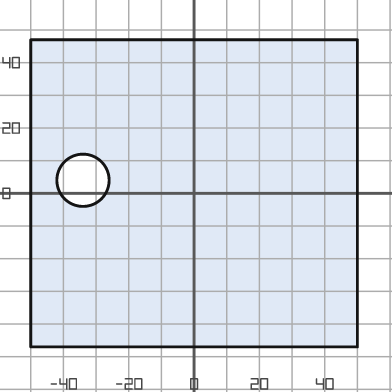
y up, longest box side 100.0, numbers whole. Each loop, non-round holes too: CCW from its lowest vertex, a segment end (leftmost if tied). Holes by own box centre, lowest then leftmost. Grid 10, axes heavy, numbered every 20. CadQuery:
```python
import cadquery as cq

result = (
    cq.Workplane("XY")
    .moveTo(-50.0, -47.0)
    .lineTo(50.0, -47.0)
    .lineTo(50.0, 47.0)
    .lineTo(-50.0, 47.0)
    .close()
    .moveTo(-34.0, 4.0)
    .circle(8.0)
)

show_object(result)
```